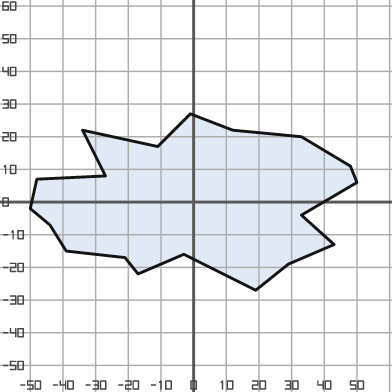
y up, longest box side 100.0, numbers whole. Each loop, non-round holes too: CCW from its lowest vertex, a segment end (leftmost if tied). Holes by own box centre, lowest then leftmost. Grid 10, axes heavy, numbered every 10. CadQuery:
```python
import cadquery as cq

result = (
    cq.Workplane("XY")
    .moveTo(19.0, -27.0)
    .lineTo(29.0, -19.0)
    .lineTo(43.0, -13.0)
    .lineTo(33.0, -4.0)
    .lineTo(50.0, 6.0)
    .lineTo(48.0, 11.0)
    .lineTo(33.0, 20.0)
    .lineTo(12.0, 22.0)
    .lineTo(-1.0, 27.0)
    .lineTo(-11.0, 17.0)
    .lineTo(-34.0, 22.0)
    .lineTo(-27.0, 8.0)
    .lineTo(-48.0, 7.0)
    .lineTo(-50.0, -2.0)
    .lineTo(-44.0, -7.0)
    .lineTo(-39.0, -15.0)
    .lineTo(-21.0, -17.0)
    .lineTo(-17.0, -22.0)
    .lineTo(-3.0, -16.0)
    .close()
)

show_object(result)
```